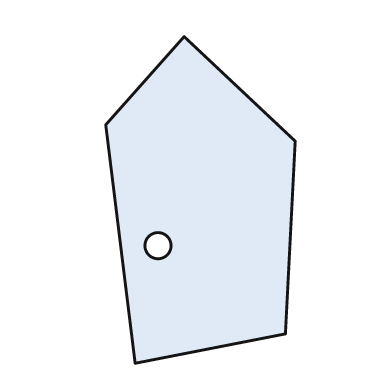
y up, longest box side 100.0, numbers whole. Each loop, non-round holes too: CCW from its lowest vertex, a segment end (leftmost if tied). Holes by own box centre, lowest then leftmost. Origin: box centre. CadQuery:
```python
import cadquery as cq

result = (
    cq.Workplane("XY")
    .moveTo(-20.0, -50.0)
    .lineTo(26.0, -41.0)
    .lineTo(29.0, 18.0)
    .lineTo(-5.0, 50.0)
    .lineTo(-29.0, 23.0)
    .close()
    .moveTo(-13.0, -14.0)
    .circle(4.0)
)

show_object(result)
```